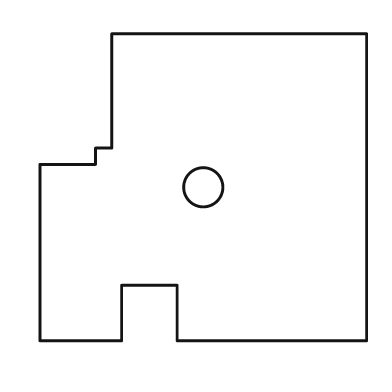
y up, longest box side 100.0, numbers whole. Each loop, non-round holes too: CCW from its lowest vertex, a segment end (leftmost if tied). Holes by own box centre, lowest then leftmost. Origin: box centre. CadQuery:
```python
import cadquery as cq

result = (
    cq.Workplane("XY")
    .moveTo(-50.0, -47.0)
    .lineTo(-25.0, -47.0)
    .lineTo(-25.0, -30.0)
    .lineTo(-8.0, -30.0)
    .lineTo(-8.0, -47.0)
    .lineTo(50.0, -47.0)
    .lineTo(50.0, 47.0)
    .lineTo(-28.0, 47.0)
    .lineTo(-28.0, 12.0)
    .lineTo(-33.0, 12.0)
    .lineTo(-33.0, 7.0)
    .lineTo(-50.0, 7.0)
    .close()
    .moveTo(0.0, 0.0)
    .circle(6.0)
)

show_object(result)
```